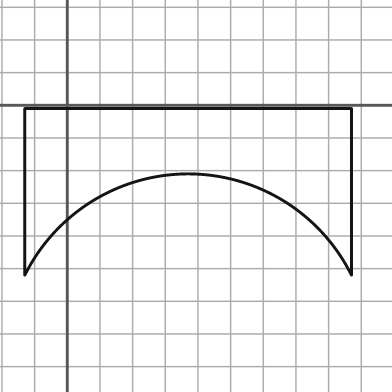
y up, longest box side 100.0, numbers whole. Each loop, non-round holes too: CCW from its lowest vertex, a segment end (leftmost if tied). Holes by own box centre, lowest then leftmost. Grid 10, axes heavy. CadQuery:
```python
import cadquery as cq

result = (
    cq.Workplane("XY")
    .moveTo(-13.0, -52.0)
    .threePointArc((37.0, -21.0), (87.0, -52.0))
    .lineTo(87.0, -1.0)
    .lineTo(-13.0, -1.0)
    .close()
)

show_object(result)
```